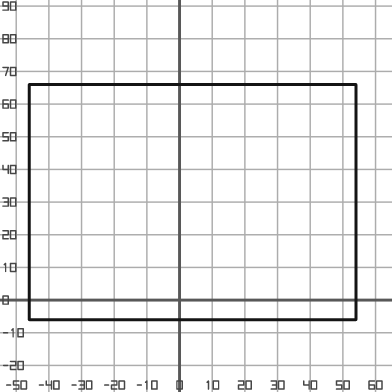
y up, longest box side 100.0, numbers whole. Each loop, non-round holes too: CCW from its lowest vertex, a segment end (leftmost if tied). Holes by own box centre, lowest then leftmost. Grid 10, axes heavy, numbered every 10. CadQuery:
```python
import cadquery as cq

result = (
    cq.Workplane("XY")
    .moveTo(-46.0, -6.0)
    .lineTo(54.0, -6.0)
    .lineTo(54.0, 66.0)
    .lineTo(-46.0, 66.0)
    .close()
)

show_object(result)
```